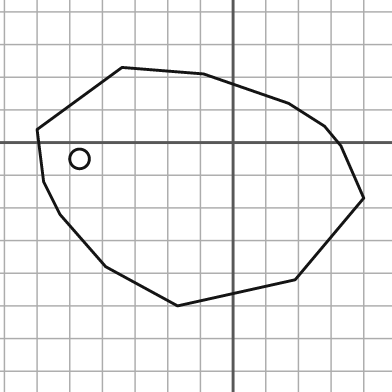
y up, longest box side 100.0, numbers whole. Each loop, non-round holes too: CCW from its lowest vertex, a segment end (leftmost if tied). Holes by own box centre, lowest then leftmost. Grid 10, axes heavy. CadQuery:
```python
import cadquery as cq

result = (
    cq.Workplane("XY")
    .moveTo(-17.0, -50.0)
    .lineTo(19.0, -42.0)
    .lineTo(40.0, -17.0)
    .lineTo(33.0, -1.0)
    .lineTo(28.0, 5.0)
    .lineTo(17.0, 12.0)
    .lineTo(-9.0, 21.0)
    .lineTo(-34.0, 23.0)
    .lineTo(-60.0, 4.0)
    .lineTo(-58.0, -12.0)
    .lineTo(-53.0, -22.0)
    .lineTo(-39.0, -38.0)
    .close()
    .moveTo(-47.0, -5.0)
    .circle(3.0)
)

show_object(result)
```